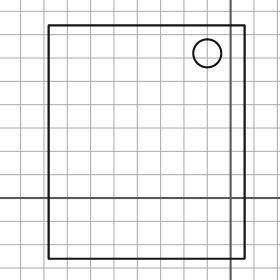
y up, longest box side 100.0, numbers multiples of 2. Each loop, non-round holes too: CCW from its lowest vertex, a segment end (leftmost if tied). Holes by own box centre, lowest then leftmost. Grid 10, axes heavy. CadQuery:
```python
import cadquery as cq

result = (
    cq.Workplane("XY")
    .moveTo(-78.0, -26.0)
    .lineTo(6.0, -26.0)
    .lineTo(6.0, 74.0)
    .lineTo(-78.0, 74.0)
    .close()
    .moveTo(-10.0, 62.0)
    .circle(6.0)
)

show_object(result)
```